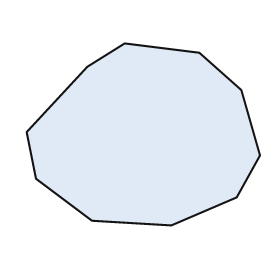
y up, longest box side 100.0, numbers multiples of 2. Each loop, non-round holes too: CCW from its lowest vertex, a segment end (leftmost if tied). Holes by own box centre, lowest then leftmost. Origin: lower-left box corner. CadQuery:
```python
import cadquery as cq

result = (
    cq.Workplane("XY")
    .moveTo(62.0, 0.0)
    .lineTo(90.0, 12.0)
    .lineTo(100.0, 30.0)
    .lineTo(92.0, 58.0)
    .lineTo(74.0, 74.0)
    .lineTo(42.0, 78.0)
    .lineTo(26.0, 68.0)
    .lineTo(0.0, 40.0)
    .lineTo(4.0, 20.0)
    .lineTo(28.0, 2.0)
    .close()
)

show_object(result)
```